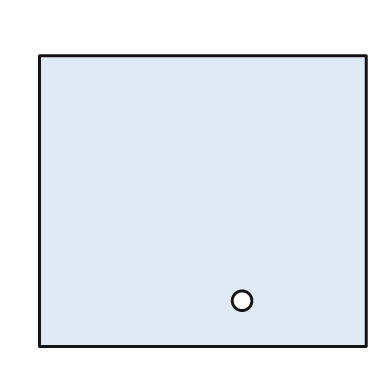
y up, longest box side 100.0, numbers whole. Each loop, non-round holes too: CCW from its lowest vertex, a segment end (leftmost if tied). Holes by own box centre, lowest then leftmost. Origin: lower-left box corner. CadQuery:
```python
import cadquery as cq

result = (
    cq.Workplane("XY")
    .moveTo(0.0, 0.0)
    .lineTo(100.0, 0.0)
    .lineTo(100.0, 89.0)
    .lineTo(0.0, 89.0)
    .close()
    .moveTo(62.0, 14.0)
    .circle(3.0)
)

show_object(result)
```